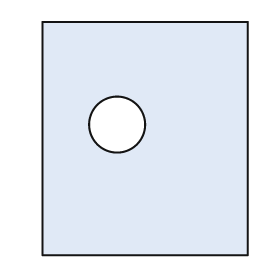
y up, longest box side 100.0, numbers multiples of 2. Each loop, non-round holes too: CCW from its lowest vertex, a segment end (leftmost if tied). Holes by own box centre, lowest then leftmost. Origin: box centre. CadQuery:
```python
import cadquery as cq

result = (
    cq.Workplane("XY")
    .moveTo(-44.0, -50.0)
    .lineTo(44.0, -50.0)
    .lineTo(44.0, 50.0)
    .lineTo(-44.0, 50.0)
    .close()
    .moveTo(-12.0, 6.0)
    .circle(12.0)
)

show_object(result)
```